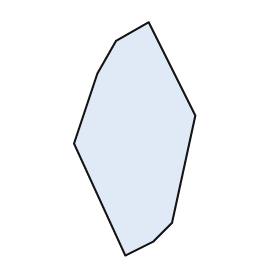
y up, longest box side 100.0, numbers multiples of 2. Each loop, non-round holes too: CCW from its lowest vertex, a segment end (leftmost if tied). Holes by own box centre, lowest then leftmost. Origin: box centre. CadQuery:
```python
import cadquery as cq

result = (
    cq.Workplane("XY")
    .moveTo(-4.0, -50.0)
    .lineTo(8.0, -44.0)
    .lineTo(16.0, -36.0)
    .lineTo(26.0, 10.0)
    .lineTo(6.0, 50.0)
    .lineTo(-8.0, 42.0)
    .lineTo(-16.0, 28.0)
    .lineTo(-26.0, -2.0)
    .close()
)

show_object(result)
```